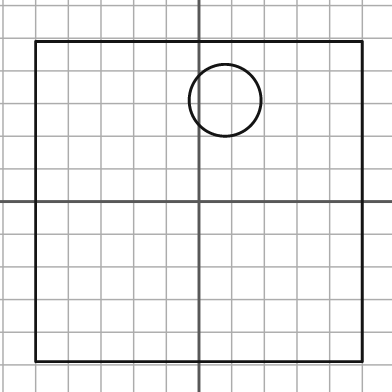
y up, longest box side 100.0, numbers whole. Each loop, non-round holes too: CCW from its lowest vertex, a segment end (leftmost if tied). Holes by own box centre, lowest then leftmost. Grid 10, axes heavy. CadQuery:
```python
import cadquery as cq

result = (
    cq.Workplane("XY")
    .moveTo(-50.0, -49.0)
    .lineTo(50.0, -49.0)
    .lineTo(50.0, 49.0)
    .lineTo(-50.0, 49.0)
    .close()
    .moveTo(8.0, 31.0)
    .circle(11.0)
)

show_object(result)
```